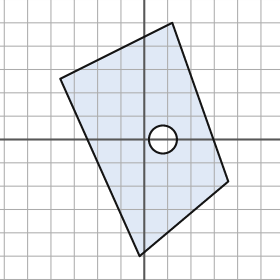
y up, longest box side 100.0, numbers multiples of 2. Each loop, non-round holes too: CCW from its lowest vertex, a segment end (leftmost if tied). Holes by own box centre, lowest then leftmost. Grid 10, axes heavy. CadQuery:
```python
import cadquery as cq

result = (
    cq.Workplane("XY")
    .moveTo(-2.0, -50.0)
    .lineTo(36.0, -18.0)
    .lineTo(12.0, 50.0)
    .lineTo(-36.0, 26.0)
    .close()
    .moveTo(8.0, 0.0)
    .circle(6.0)
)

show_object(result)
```